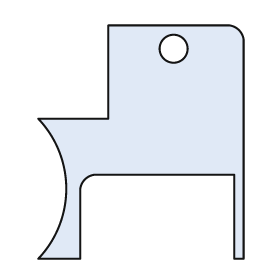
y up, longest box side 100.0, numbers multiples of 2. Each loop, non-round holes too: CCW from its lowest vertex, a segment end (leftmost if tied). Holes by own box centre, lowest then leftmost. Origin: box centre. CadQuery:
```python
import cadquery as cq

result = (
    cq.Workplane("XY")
    .moveTo(-44.0, -50.0)
    .lineTo(-26.0, -50.0)
    .lineTo(-26.0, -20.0)
    .threePointArc((-24.0, -16.0), (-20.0, -14.0))
    .lineTo(40.0, -14.0)
    .lineTo(40.0, -50.0)
    .lineTo(44.0, -50.0)
    .lineTo(44.0, 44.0)
    .threePointArc((42.0, 48.0), (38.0, 50.0))
    .lineTo(-14.0, 50.0)
    .lineTo(-14.0, 10.0)
    .lineTo(-44.0, 10.0)
    .threePointArc((-32.0, -20.0), (-44.0, -50.0))
    .close()
    .moveTo(14.0, 40.0)
    .circle(6.0)
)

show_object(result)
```